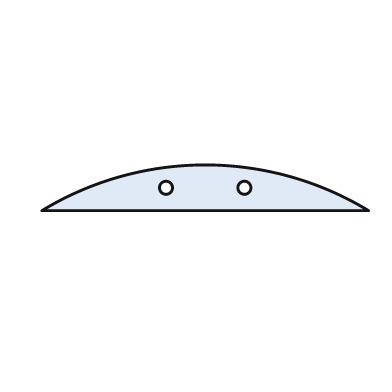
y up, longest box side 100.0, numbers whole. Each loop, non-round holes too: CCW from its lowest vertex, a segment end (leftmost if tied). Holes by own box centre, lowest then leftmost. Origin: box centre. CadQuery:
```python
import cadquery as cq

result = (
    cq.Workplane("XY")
    .moveTo(-50.0, -7.0)
    .lineTo(50.0, -7.0)
    .threePointArc((0.0, 7.0), (-50.0, -7.0))
    .close()
    .moveTo(-12.0, 0.0)
    .circle(2.0)
    .moveTo(12.0, 0.0)
    .circle(2.0)
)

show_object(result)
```